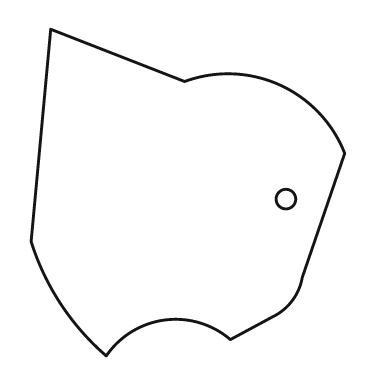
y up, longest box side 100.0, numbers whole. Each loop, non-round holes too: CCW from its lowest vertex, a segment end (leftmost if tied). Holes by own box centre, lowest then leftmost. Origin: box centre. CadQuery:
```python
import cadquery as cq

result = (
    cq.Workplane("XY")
    .moveTo(-25.0, -50.0)
    .threePointArc((-7.0, -39.0), (13.0, -45.0))
    .lineTo(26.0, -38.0)
    .threePointArc((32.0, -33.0), (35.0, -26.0))
    .lineTo(48.0, 12.0)
    .threePointArc((28.0, 33.0), (-1.0, 34.0))
    .lineTo(-42.0, 50.0)
    .lineTo(-48.0, -15.0)
    .threePointArc((-39.0, -34.0), (-25.0, -50.0))
    .close()
    .moveTo(30.0, -2.0)
    .circle(3.0)
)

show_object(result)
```